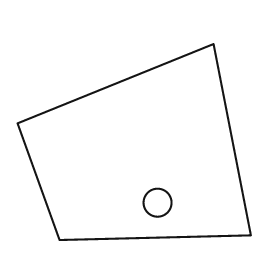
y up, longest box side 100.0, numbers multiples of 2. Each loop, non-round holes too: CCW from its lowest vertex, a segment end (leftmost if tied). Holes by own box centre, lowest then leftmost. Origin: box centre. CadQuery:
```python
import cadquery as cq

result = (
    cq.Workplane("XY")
    .moveTo(-32.0, -42.0)
    .lineTo(50.0, -40.0)
    .lineTo(34.0, 42.0)
    .lineTo(-50.0, 8.0)
    .close()
    .moveTo(10.0, -26.0)
    .circle(6.0)
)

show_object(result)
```